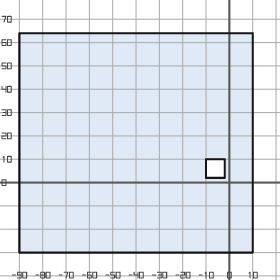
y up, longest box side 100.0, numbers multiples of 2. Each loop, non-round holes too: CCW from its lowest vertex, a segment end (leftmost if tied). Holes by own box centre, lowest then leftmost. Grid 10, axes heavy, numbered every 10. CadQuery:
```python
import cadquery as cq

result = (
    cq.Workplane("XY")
    .moveTo(-90.0, -30.0)
    .lineTo(10.0, -30.0)
    .lineTo(10.0, 64.0)
    .lineTo(-90.0, 64.0)
    .close()
    .moveTo(-10.0, 2.0)
    .lineTo(-2.0, 2.0)
    .lineTo(-2.0, 10.0)
    .lineTo(-10.0, 10.0)
    .close()
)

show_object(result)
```